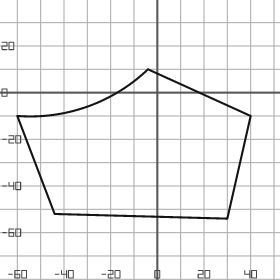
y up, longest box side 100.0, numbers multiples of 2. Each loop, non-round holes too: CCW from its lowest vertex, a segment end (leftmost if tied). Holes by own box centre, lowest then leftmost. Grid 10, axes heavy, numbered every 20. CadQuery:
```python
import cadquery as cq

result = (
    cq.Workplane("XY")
    .moveTo(30.0, -54.0)
    .lineTo(40.0, -10.0)
    .lineTo(-4.0, 10.0)
    .threePointArc((-30.0, -6.0), (-60.0, -10.0))
    .lineTo(-44.0, -52.0)
    .close()
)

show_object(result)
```